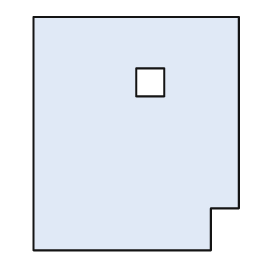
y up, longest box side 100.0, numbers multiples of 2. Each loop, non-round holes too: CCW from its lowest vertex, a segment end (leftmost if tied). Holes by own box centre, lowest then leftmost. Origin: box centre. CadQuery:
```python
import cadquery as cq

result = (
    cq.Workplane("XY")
    .moveTo(-44.0, -50.0)
    .lineTo(32.0, -50.0)
    .lineTo(32.0, -32.0)
    .lineTo(44.0, -32.0)
    .lineTo(44.0, 50.0)
    .lineTo(-44.0, 50.0)
    .close()
    .moveTo(0.0, 16.0)
    .lineTo(12.0, 16.0)
    .lineTo(12.0, 28.0)
    .lineTo(0.0, 28.0)
    .close()
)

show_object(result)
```